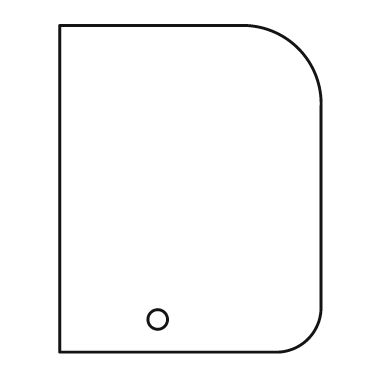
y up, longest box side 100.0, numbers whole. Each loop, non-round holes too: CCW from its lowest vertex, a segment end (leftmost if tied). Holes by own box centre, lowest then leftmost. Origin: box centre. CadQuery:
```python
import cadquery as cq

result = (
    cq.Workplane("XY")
    .moveTo(-40.0, -50.0)
    .lineTo(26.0, -50.0)
    .threePointArc((36.0, -46.0), (40.0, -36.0))
    .lineTo(40.0, 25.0)
    .threePointArc((33.0, 43.0), (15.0, 50.0))
    .lineTo(-40.0, 50.0)
    .close()
    .moveTo(-10.0, -40.0)
    .circle(3.0)
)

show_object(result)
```